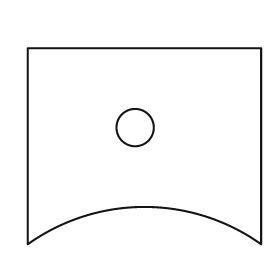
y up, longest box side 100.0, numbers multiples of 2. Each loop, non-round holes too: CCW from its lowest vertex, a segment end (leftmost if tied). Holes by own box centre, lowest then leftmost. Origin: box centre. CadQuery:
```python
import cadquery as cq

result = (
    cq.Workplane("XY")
    .moveTo(-50.0, -42.0)
    .threePointArc((0.0, -26.0), (50.0, -42.0))
    .lineTo(50.0, 42.0)
    .lineTo(-50.0, 42.0)
    .close()
    .moveTo(-4.0, 8.0)
    .circle(8.0)
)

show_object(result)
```